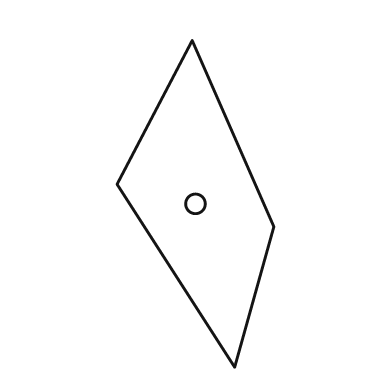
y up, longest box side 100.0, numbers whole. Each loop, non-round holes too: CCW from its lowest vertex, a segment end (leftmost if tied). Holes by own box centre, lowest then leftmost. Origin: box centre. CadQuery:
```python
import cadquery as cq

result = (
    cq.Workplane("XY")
    .moveTo(12.0, -50.0)
    .lineTo(24.0, -7.0)
    .lineTo(-1.0, 50.0)
    .lineTo(-24.0, 6.0)
    .close()
    .moveTo(0.0, 0.0)
    .circle(3.0)
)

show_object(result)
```